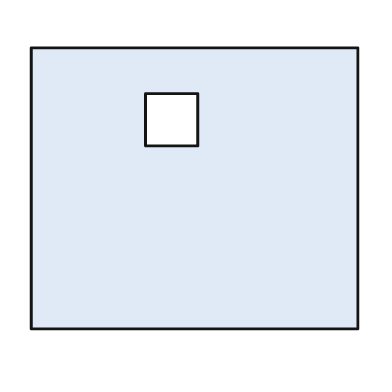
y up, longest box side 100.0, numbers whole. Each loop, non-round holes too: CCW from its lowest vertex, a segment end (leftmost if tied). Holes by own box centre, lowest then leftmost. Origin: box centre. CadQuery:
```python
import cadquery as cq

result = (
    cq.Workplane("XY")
    .moveTo(-50.0, -43.0)
    .lineTo(50.0, -43.0)
    .lineTo(50.0, 43.0)
    .lineTo(-50.0, 43.0)
    .close()
    .moveTo(-15.0, 13.0)
    .lineTo(1.0, 13.0)
    .lineTo(1.0, 29.0)
    .lineTo(-15.0, 29.0)
    .close()
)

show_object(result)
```